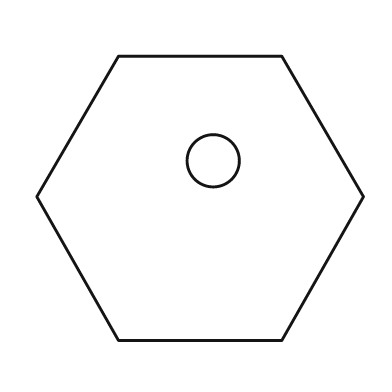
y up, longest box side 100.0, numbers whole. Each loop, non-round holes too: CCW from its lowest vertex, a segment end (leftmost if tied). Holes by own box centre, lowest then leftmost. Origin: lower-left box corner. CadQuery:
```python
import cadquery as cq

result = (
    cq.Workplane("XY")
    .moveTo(25.0, 0.0)
    .lineTo(75.0, 0.0)
    .lineTo(100.0, 44.0)
    .lineTo(75.0, 87.0)
    .lineTo(25.0, 87.0)
    .lineTo(0.0, 44.0)
    .close()
    .moveTo(54.0, 55.0)
    .circle(8.0)
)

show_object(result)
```